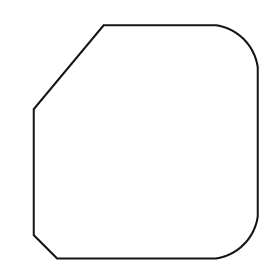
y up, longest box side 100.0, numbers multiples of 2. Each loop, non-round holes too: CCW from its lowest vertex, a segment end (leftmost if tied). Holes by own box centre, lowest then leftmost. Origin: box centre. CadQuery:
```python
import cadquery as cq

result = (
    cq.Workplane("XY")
    .moveTo(-38.0, -50.0)
    .lineTo(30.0, -50.0)
    .threePointArc((42.0, -44.0), (48.0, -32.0))
    .lineTo(48.0, 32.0)
    .threePointArc((42.0, 44.0), (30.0, 50.0))
    .lineTo(-18.0, 50.0)
    .lineTo(-48.0, 14.0)
    .lineTo(-48.0, -40.0)
    .close()
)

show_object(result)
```